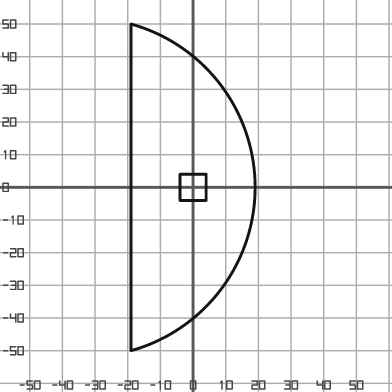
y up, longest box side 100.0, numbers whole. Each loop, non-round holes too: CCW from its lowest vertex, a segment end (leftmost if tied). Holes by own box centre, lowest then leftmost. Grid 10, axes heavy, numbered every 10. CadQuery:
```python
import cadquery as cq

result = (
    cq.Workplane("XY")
    .moveTo(-19.0, -50.0)
    .threePointArc((19.0, 0.0), (-19.0, 50.0))
    .close()
    .moveTo(-4.0, -4.0)
    .lineTo(4.0, -4.0)
    .lineTo(4.0, 4.0)
    .lineTo(-4.0, 4.0)
    .close()
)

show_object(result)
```